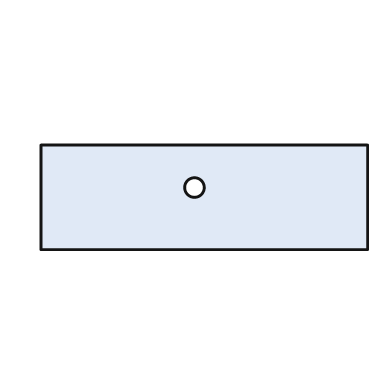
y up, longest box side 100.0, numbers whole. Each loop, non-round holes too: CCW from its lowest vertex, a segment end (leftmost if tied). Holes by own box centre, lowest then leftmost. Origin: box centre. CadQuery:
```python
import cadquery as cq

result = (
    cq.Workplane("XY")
    .moveTo(-50.0, -16.0)
    .lineTo(50.0, -16.0)
    .lineTo(50.0, 16.0)
    .lineTo(-50.0, 16.0)
    .close()
    .moveTo(-3.0, 3.0)
    .circle(3.0)
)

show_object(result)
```